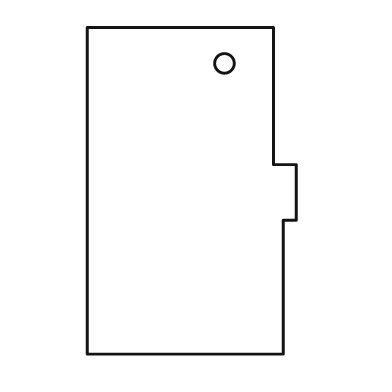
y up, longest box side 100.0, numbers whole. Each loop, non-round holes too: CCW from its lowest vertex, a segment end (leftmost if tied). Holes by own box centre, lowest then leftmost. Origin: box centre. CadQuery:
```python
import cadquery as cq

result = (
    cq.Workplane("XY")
    .moveTo(-32.0, -50.0)
    .lineTo(28.0, -50.0)
    .lineTo(28.0, -9.0)
    .lineTo(32.0, -9.0)
    .lineTo(32.0, 8.0)
    .lineTo(25.0, 8.0)
    .lineTo(25.0, 50.0)
    .lineTo(-32.0, 50.0)
    .close()
    .moveTo(10.0, 39.0)
    .circle(3.0)
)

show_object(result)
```